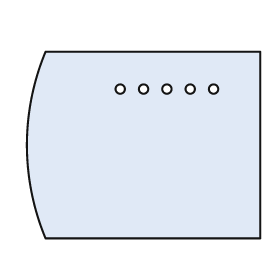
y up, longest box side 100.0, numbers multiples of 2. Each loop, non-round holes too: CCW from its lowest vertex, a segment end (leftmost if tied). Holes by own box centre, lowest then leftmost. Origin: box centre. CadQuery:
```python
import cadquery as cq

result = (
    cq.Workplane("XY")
    .moveTo(-42.0, -40.0)
    .lineTo(50.0, -40.0)
    .lineTo(50.0, 40.0)
    .lineTo(-42.0, 40.0)
    .threePointArc((-50.0, 0.0), (-42.0, -40.0))
    .close()
    .moveTo(-10.0, 24.0)
    .circle(2.0)
    .moveTo(0.0, 24.0)
    .circle(2.0)
    .moveTo(10.0, 24.0)
    .circle(2.0)
    .moveTo(20.0, 24.0)
    .circle(2.0)
    .moveTo(30.0, 24.0)
    .circle(2.0)
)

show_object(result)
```